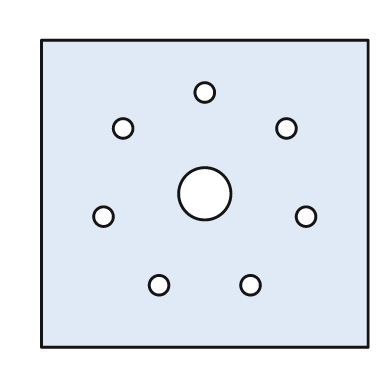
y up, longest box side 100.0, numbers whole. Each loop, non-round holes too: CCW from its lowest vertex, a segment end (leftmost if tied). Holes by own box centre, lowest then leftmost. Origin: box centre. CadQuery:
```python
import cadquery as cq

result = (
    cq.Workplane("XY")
    .moveTo(-50.0, -47.0)
    .lineTo(50.0, -47.0)
    .lineTo(50.0, 47.0)
    .lineTo(-50.0, 47.0)
    .close()
    .moveTo(-14.0, -28.0)
    .circle(3.0)
    .moveTo(14.0, -28.0)
    .circle(3.0)
    .moveTo(-31.0, -7.0)
    .circle(3.0)
    .moveTo(31.0, -7.0)
    .circle(3.0)
    .moveTo(0.0, 0.0)
    .circle(8.0)
    .moveTo(-25.0, 20.0)
    .circle(3.0)
    .moveTo(25.0, 20.0)
    .circle(3.0)
    .moveTo(0.0, 31.0)
    .circle(3.0)
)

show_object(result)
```